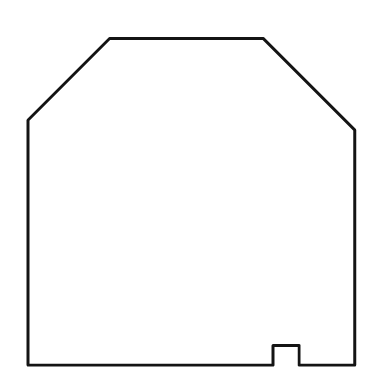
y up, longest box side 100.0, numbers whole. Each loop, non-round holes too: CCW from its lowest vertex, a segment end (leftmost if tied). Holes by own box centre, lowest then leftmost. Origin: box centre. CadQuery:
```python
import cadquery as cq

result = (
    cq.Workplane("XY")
    .moveTo(-50.0, -50.0)
    .lineTo(25.0, -50.0)
    .lineTo(25.0, -44.0)
    .lineTo(33.0, -44.0)
    .lineTo(33.0, -50.0)
    .lineTo(50.0, -50.0)
    .lineTo(50.0, 22.0)
    .lineTo(22.0, 50.0)
    .lineTo(-25.0, 50.0)
    .lineTo(-50.0, 25.0)
    .close()
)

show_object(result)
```